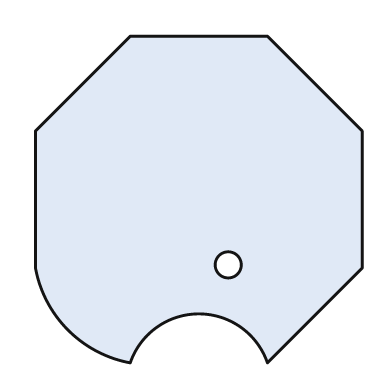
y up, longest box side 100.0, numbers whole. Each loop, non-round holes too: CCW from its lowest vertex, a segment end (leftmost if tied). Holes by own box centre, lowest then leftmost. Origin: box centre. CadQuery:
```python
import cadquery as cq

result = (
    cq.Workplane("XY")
    .moveTo(-21.0, -50.0)
    .threePointArc((0.0, -35.0), (21.0, -50.0))
    .lineTo(50.0, -21.0)
    .lineTo(50.0, 21.0)
    .lineTo(21.0, 50.0)
    .lineTo(-21.0, 50.0)
    .lineTo(-50.0, 21.0)
    .lineTo(-50.0, -21.0)
    .threePointArc((-40.0, -40.0), (-21.0, -50.0))
    .close()
    .moveTo(9.0, -20.0)
    .circle(4.0)
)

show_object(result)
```